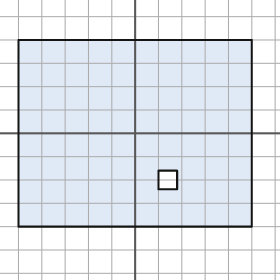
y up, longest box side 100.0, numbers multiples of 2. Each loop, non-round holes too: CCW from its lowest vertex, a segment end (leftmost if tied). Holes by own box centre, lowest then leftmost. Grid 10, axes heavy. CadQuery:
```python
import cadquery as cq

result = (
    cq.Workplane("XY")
    .moveTo(-50.0, -40.0)
    .lineTo(50.0, -40.0)
    .lineTo(50.0, 40.0)
    .lineTo(-50.0, 40.0)
    .close()
    .moveTo(10.0, -24.0)
    .lineTo(18.0, -24.0)
    .lineTo(18.0, -16.0)
    .lineTo(10.0, -16.0)
    .close()
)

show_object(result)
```